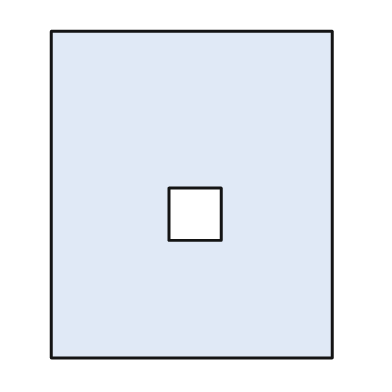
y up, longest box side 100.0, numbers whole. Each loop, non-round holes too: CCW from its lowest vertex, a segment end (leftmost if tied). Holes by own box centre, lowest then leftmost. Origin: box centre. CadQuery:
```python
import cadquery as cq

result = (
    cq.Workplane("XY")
    .moveTo(-43.0, -50.0)
    .lineTo(43.0, -50.0)
    .lineTo(43.0, 50.0)
    .lineTo(-43.0, 50.0)
    .close()
    .moveTo(-7.0, -14.0)
    .lineTo(9.0, -14.0)
    .lineTo(9.0, 2.0)
    .lineTo(-7.0, 2.0)
    .close()
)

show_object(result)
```